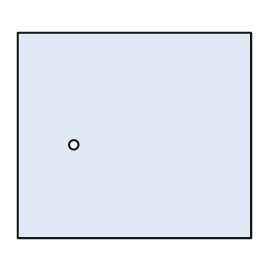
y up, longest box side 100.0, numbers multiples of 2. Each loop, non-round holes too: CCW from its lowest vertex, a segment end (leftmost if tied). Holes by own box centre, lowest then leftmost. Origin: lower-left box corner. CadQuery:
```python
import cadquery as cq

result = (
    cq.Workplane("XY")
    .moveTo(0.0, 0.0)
    .lineTo(100.0, 0.0)
    .lineTo(100.0, 88.0)
    .lineTo(0.0, 88.0)
    .close()
    .moveTo(24.0, 40.0)
    .circle(2.0)
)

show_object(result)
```